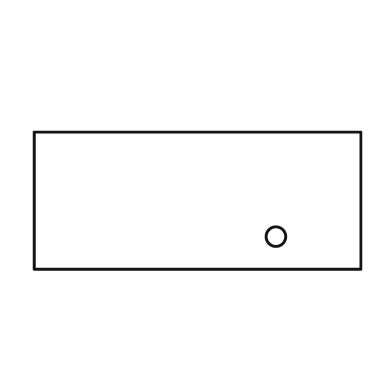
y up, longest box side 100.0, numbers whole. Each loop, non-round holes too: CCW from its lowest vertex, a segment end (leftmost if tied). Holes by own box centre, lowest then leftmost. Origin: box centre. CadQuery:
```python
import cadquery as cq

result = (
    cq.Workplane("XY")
    .moveTo(-50.0, -21.0)
    .lineTo(50.0, -21.0)
    .lineTo(50.0, 21.0)
    .lineTo(-50.0, 21.0)
    .close()
    .moveTo(24.0, -11.0)
    .circle(3.0)
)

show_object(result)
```